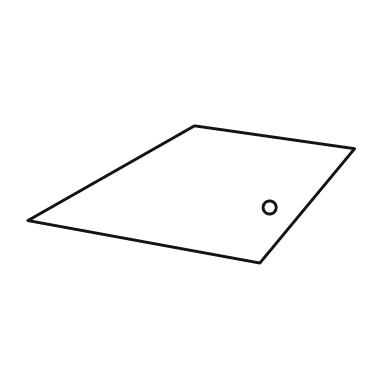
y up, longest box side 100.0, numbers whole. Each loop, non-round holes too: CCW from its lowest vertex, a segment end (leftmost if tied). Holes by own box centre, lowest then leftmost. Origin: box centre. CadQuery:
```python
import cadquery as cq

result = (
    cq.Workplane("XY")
    .moveTo(21.0, -21.0)
    .lineTo(50.0, 14.0)
    .lineTo(1.0, 21.0)
    .lineTo(-50.0, -8.0)
    .close()
    .moveTo(24.0, -4.0)
    .circle(2.0)
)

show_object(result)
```